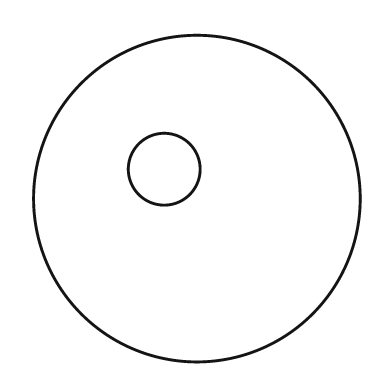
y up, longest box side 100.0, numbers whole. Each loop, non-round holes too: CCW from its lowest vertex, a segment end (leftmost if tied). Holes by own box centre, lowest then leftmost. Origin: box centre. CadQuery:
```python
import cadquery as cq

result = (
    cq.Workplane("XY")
    .moveTo(0.0, 0.0)
    .circle(50.0)
    .moveTo(-10.0, 9.0)
    .circle(11.0)
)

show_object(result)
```